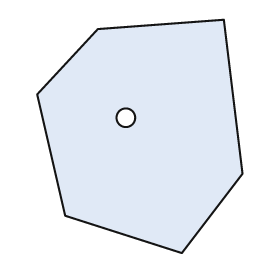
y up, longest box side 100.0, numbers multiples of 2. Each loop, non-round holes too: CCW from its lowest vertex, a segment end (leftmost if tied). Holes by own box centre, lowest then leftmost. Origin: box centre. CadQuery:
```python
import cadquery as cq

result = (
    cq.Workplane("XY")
    .moveTo(18.0, -50.0)
    .lineTo(44.0, -16.0)
    .lineTo(36.0, 50.0)
    .lineTo(-18.0, 46.0)
    .lineTo(-44.0, 18.0)
    .lineTo(-32.0, -34.0)
    .close()
    .moveTo(-6.0, 8.0)
    .circle(4.0)
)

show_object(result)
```